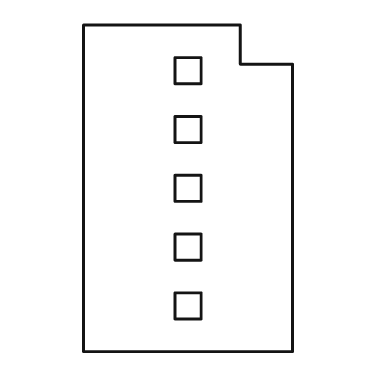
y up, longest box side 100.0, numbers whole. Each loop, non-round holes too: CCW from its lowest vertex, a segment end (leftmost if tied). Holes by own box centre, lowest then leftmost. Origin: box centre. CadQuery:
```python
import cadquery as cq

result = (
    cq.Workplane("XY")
    .moveTo(-32.0, -50.0)
    .lineTo(32.0, -50.0)
    .lineTo(32.0, 38.0)
    .lineTo(16.0, 38.0)
    .lineTo(16.0, 50.0)
    .lineTo(-32.0, 50.0)
    .close()
    .moveTo(-4.0, -40.0)
    .lineTo(4.0, -40.0)
    .lineTo(4.0, -32.0)
    .lineTo(-4.0, -32.0)
    .close()
    .moveTo(-4.0, -22.0)
    .lineTo(4.0, -22.0)
    .lineTo(4.0, -14.0)
    .lineTo(-4.0, -14.0)
    .close()
    .moveTo(-4.0, -4.0)
    .lineTo(4.0, -4.0)
    .lineTo(4.0, 4.0)
    .lineTo(-4.0, 4.0)
    .close()
    .moveTo(-4.0, 14.0)
    .lineTo(4.0, 14.0)
    .lineTo(4.0, 22.0)
    .lineTo(-4.0, 22.0)
    .close()
    .moveTo(-4.0, 32.0)
    .lineTo(4.0, 32.0)
    .lineTo(4.0, 40.0)
    .lineTo(-4.0, 40.0)
    .close()
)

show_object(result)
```